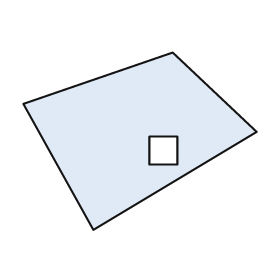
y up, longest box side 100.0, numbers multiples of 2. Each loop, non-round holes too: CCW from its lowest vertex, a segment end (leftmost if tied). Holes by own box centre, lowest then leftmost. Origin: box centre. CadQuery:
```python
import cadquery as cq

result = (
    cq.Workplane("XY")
    .moveTo(-20.0, -38.0)
    .lineTo(50.0, 4.0)
    .lineTo(14.0, 38.0)
    .lineTo(-50.0, 16.0)
    .close()
    .moveTo(4.0, -10.0)
    .lineTo(16.0, -10.0)
    .lineTo(16.0, 2.0)
    .lineTo(4.0, 2.0)
    .close()
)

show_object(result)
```